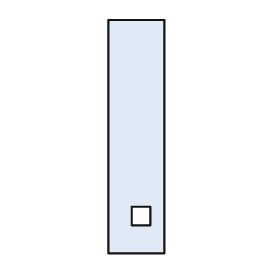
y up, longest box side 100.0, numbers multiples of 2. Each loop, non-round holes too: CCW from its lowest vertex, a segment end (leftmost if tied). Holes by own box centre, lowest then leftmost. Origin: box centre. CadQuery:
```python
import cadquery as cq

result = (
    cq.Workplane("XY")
    .moveTo(-12.0, -50.0)
    .lineTo(12.0, -50.0)
    .lineTo(12.0, 50.0)
    .lineTo(-12.0, 50.0)
    .close()
    .moveTo(-2.0, -38.0)
    .lineTo(6.0, -38.0)
    .lineTo(6.0, -30.0)
    .lineTo(-2.0, -30.0)
    .close()
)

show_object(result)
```